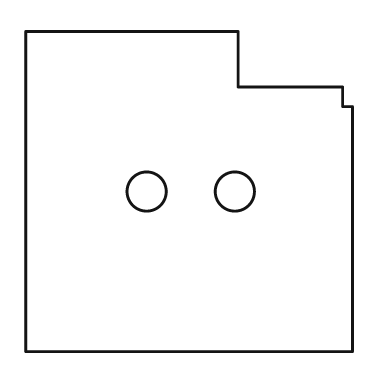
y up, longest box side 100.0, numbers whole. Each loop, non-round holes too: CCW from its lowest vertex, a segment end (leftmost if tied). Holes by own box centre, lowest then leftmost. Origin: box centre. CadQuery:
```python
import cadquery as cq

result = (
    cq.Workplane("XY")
    .moveTo(-50.0, -49.0)
    .lineTo(50.0, -49.0)
    .lineTo(50.0, 26.0)
    .lineTo(47.0, 26.0)
    .lineTo(47.0, 32.0)
    .lineTo(15.0, 32.0)
    .lineTo(15.0, 49.0)
    .lineTo(-50.0, 49.0)
    .close()
    .moveTo(-13.0, 0.0)
    .circle(6.0)
    .moveTo(14.0, 0.0)
    .circle(6.0)
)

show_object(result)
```